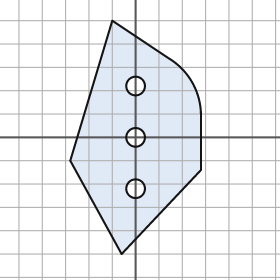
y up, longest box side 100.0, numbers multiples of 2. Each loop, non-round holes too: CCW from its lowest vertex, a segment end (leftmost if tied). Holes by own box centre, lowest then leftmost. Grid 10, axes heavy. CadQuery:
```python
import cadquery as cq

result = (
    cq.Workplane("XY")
    .moveTo(-6.0, -50.0)
    .lineTo(28.0, -14.0)
    .lineTo(28.0, 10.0)
    .threePointArc((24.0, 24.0), (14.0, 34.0))
    .lineTo(-10.0, 50.0)
    .lineTo(-28.0, -10.0)
    .close()
    .moveTo(0.0, -22.0)
    .circle(4.0)
    .moveTo(0.0, 0.0)
    .circle(4.0)
    .moveTo(0.0, 22.0)
    .circle(4.0)
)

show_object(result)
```